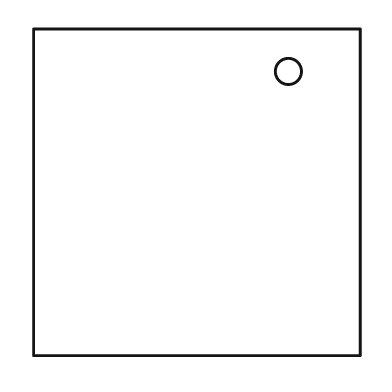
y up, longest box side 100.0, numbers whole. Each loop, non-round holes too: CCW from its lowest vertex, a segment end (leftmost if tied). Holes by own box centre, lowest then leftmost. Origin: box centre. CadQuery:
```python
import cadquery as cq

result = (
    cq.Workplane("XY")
    .moveTo(-50.0, -50.0)
    .lineTo(50.0, -50.0)
    .lineTo(50.0, 50.0)
    .lineTo(-50.0, 50.0)
    .close()
    .moveTo(28.0, 37.0)
    .circle(4.0)
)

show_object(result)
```